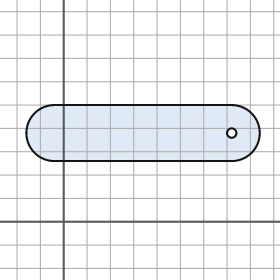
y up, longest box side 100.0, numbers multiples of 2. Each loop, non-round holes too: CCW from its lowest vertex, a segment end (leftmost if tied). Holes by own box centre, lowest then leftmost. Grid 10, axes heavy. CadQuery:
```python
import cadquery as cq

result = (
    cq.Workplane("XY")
    .moveTo(-4.0, 26.0)
    .lineTo(72.0, 26.0)
    .threePointArc((84.0, 38.0), (72.0, 50.0))
    .lineTo(-4.0, 50.0)
    .threePointArc((-16.0, 38.0), (-4.0, 26.0))
    .close()
    .moveTo(72.0, 38.0)
    .circle(2.0)
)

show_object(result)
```